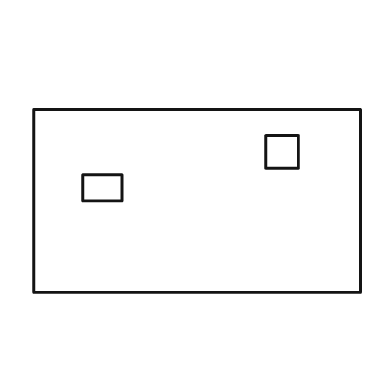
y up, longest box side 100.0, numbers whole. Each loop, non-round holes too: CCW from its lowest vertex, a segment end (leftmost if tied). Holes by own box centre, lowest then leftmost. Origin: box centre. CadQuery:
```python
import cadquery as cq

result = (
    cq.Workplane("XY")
    .moveTo(-50.0, -28.0)
    .lineTo(50.0, -28.0)
    .lineTo(50.0, 28.0)
    .lineTo(-50.0, 28.0)
    .close()
    .moveTo(-35.0, 0.0)
    .lineTo(-23.0, 0.0)
    .lineTo(-23.0, 8.0)
    .lineTo(-35.0, 8.0)
    .close()
    .moveTo(21.0, 10.0)
    .lineTo(31.0, 10.0)
    .lineTo(31.0, 20.0)
    .lineTo(21.0, 20.0)
    .close()
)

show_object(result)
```